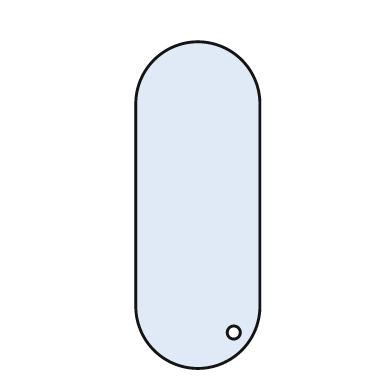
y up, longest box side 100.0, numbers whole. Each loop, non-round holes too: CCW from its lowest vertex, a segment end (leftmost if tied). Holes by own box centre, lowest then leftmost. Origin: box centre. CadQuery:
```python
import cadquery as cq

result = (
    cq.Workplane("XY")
    .moveTo(-19.0, -31.0)
    .threePointArc((0.0, -50.0), (19.0, -31.0))
    .lineTo(19.0, 31.0)
    .threePointArc((0.0, 50.0), (-19.0, 31.0))
    .close()
    .moveTo(11.0, -39.0)
    .circle(2.0)
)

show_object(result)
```